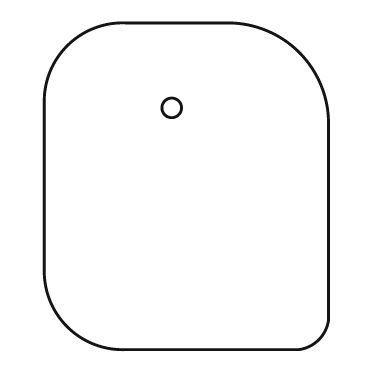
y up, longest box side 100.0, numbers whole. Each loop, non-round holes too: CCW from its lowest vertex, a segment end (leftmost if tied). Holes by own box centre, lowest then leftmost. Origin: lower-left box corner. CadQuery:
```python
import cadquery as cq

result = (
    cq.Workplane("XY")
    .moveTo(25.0, 0.0)
    .lineTo(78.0, 0.0)
    .threePointArc((84.0, 3.0), (87.0, 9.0))
    .lineTo(87.0, 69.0)
    .threePointArc((78.0, 91.0), (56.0, 100.0))
    .lineTo(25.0, 100.0)
    .threePointArc((7.0, 93.0), (0.0, 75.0))
    .lineTo(0.0, 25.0)
    .threePointArc((7.0, 7.0), (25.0, 0.0))
    .close()
    .moveTo(39.0, 74.0)
    .circle(3.0)
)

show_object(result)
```